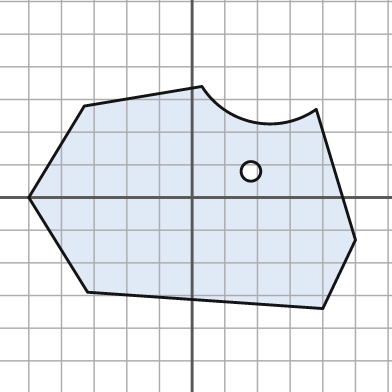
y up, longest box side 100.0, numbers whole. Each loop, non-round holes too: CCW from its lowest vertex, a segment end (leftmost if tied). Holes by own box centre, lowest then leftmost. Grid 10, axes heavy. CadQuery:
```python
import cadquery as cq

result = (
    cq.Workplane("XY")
    .moveTo(40.0, -34.0)
    .lineTo(50.0, -13.0)
    .lineTo(38.0, 27.0)
    .threePointArc((19.0, 23.0), (3.0, 34.0))
    .lineTo(-33.0, 28.0)
    .lineTo(-50.0, 0.0)
    .lineTo(-32.0, -29.0)
    .close()
    .moveTo(18.0, 8.0)
    .circle(3.0)
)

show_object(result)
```